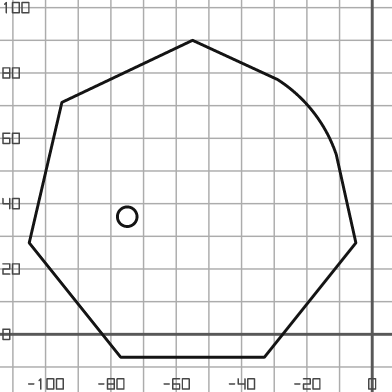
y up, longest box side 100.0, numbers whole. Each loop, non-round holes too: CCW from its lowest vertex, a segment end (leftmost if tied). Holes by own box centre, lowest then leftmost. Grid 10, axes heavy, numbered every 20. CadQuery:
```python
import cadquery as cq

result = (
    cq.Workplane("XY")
    .moveTo(-77.0, -7.0)
    .lineTo(-33.0, -7.0)
    .lineTo(-5.0, 28.0)
    .lineTo(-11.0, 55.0)
    .threePointArc((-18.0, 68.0), (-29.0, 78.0))
    .lineTo(-55.0, 90.0)
    .lineTo(-95.0, 71.0)
    .lineTo(-105.0, 28.0)
    .close()
    .moveTo(-75.0, 36.0)
    .circle(3.0)
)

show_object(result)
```